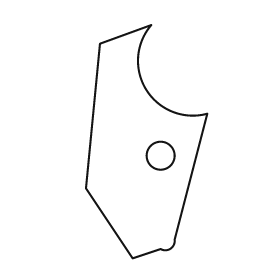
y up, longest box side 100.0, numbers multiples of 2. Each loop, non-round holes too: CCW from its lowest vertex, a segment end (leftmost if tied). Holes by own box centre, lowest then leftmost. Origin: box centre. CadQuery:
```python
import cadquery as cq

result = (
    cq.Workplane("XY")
    .moveTo(-6.0, -50.0)
    .lineTo(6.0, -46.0)
    .threePointArc((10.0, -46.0), (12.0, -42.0))
    .lineTo(26.0, 12.0)
    .threePointArc((0.0, 22.0), (2.0, 50.0))
    .lineTo(-20.0, 42.0)
    .lineTo(-26.0, -20.0)
    .close()
    .moveTo(6.0, -6.0)
    .circle(6.0)
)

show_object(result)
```